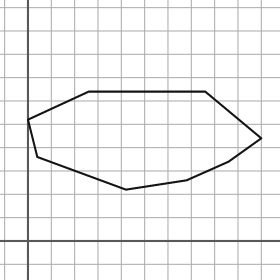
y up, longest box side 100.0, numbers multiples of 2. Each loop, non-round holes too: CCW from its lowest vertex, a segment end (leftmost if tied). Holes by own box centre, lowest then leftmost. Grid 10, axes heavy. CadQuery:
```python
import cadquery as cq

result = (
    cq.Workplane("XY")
    .moveTo(42.0, 22.0)
    .lineTo(68.0, 26.0)
    .lineTo(86.0, 34.0)
    .lineTo(100.0, 44.0)
    .lineTo(76.0, 64.0)
    .lineTo(26.0, 64.0)
    .lineTo(0.0, 52.0)
    .lineTo(4.0, 36.0)
    .close()
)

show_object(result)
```